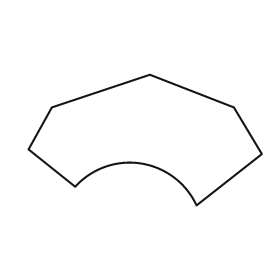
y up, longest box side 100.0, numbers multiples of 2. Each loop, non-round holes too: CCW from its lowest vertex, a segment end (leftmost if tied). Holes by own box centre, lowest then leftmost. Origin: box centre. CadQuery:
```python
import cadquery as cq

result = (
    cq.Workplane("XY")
    .moveTo(22.0, -28.0)
    .lineTo(50.0, -6.0)
    .lineTo(38.0, 14.0)
    .lineTo(2.0, 28.0)
    .lineTo(-40.0, 14.0)
    .lineTo(-50.0, -4.0)
    .lineTo(-30.0, -20.0)
    .threePointArc((-2.0, -10.0), (22.0, -28.0))
    .close()
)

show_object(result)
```